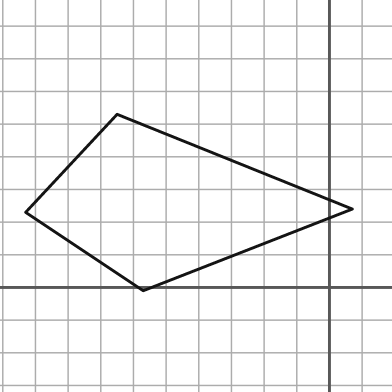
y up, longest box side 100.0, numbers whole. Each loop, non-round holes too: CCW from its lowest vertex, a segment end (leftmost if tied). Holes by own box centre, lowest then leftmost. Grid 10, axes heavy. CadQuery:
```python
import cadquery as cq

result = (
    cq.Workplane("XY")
    .moveTo(-57.0, -1.0)
    .lineTo(7.0, 24.0)
    .lineTo(-65.0, 53.0)
    .lineTo(-93.0, 23.0)
    .close()
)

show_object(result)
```